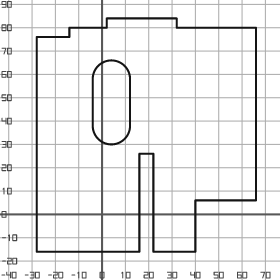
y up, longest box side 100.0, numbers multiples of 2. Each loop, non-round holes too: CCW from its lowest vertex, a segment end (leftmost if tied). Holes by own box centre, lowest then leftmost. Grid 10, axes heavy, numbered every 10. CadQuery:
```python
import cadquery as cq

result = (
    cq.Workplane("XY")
    .moveTo(-28.0, -16.0)
    .lineTo(16.0, -16.0)
    .lineTo(16.0, 26.0)
    .lineTo(22.0, 26.0)
    .lineTo(22.0, -16.0)
    .lineTo(40.0, -16.0)
    .lineTo(40.0, 6.0)
    .lineTo(66.0, 6.0)
    .lineTo(66.0, 80.0)
    .lineTo(32.0, 80.0)
    .lineTo(32.0, 84.0)
    .lineTo(2.0, 84.0)
    .lineTo(2.0, 80.0)
    .lineTo(-14.0, 80.0)
    .lineTo(-14.0, 76.0)
    .lineTo(-28.0, 76.0)
    .close()
    .moveTo(-4.0, 38.0)
    .threePointArc((4.0, 30.0), (12.0, 38.0))
    .lineTo(12.0, 58.0)
    .threePointArc((4.0, 66.0), (-4.0, 58.0))
    .close()
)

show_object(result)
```